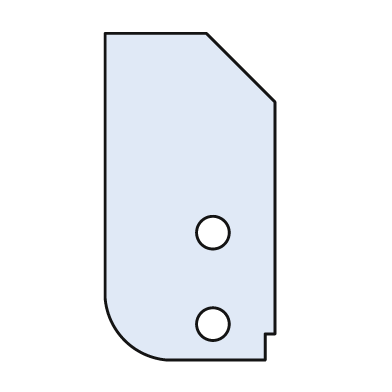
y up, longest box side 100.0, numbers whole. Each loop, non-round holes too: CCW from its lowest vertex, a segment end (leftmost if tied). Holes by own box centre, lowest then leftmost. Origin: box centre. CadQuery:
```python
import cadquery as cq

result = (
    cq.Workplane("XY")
    .moveTo(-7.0, -50.0)
    .lineTo(23.0, -50.0)
    .lineTo(23.0, -42.0)
    .lineTo(26.0, -42.0)
    .lineTo(26.0, 29.0)
    .lineTo(5.0, 50.0)
    .lineTo(-26.0, 50.0)
    .lineTo(-26.0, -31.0)
    .threePointArc((-20.0, -44.0), (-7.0, -50.0))
    .close()
    .moveTo(7.0, -39.0)
    .circle(5.0)
    .moveTo(7.0, -11.0)
    .circle(5.0)
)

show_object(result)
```